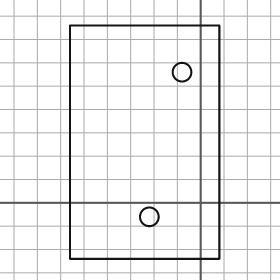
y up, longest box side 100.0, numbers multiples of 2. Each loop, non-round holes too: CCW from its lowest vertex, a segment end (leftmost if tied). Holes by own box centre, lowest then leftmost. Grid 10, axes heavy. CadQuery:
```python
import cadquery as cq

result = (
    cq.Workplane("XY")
    .moveTo(-56.0, -24.0)
    .lineTo(8.0, -24.0)
    .lineTo(8.0, 76.0)
    .lineTo(-56.0, 76.0)
    .close()
    .moveTo(-22.0, -6.0)
    .circle(4.0)
    .moveTo(-8.0, 56.0)
    .circle(4.0)
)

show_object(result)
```